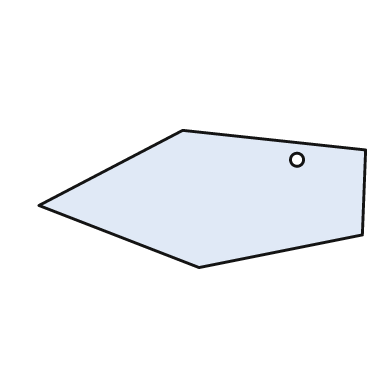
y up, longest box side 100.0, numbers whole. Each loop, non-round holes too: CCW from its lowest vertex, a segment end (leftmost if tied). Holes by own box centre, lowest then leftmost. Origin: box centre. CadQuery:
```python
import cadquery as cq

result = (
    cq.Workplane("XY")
    .moveTo(-1.0, -21.0)
    .lineTo(49.0, -11.0)
    .lineTo(50.0, 15.0)
    .lineTo(-6.0, 21.0)
    .lineTo(-50.0, -2.0)
    .close()
    .moveTo(29.0, 12.0)
    .circle(2.0)
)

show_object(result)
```